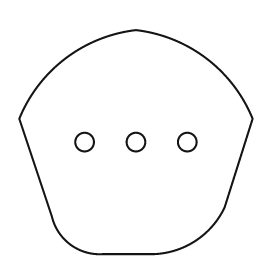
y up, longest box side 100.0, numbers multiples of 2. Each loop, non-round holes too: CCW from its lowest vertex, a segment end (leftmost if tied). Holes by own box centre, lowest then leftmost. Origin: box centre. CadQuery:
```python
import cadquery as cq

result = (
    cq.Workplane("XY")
    .moveTo(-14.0, -48.0)
    .lineTo(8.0, -48.0)
    .threePointArc((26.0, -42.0), (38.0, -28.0))
    .lineTo(50.0, 10.0)
    .threePointArc((30.0, 36.0), (0.0, 48.0))
    .threePointArc((-30.0, 36.0), (-50.0, 10.0))
    .lineTo(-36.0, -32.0)
    .threePointArc((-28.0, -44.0), (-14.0, -48.0))
    .close()
    .moveTo(-22.0, 0.0)
    .circle(4.0)
    .moveTo(0.0, 0.0)
    .circle(4.0)
    .moveTo(22.0, 0.0)
    .circle(4.0)
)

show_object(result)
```